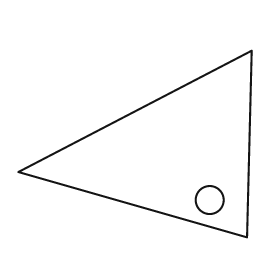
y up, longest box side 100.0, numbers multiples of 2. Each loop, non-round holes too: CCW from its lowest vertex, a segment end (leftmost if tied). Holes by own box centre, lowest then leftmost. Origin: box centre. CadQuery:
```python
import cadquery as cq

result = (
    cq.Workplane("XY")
    .moveTo(48.0, -40.0)
    .lineTo(50.0, 40.0)
    .lineTo(-50.0, -12.0)
    .close()
    .moveTo(32.0, -24.0)
    .circle(6.0)
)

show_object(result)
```